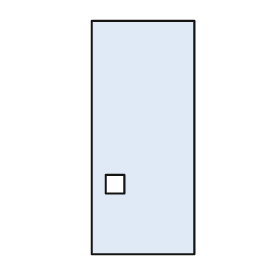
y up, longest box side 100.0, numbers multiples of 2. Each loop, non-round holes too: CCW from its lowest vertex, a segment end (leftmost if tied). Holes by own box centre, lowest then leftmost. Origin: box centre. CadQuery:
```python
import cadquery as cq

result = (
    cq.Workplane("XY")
    .moveTo(-22.0, -50.0)
    .lineTo(22.0, -50.0)
    .lineTo(22.0, 50.0)
    .lineTo(-22.0, 50.0)
    .close()
    .moveTo(-16.0, -24.0)
    .lineTo(-8.0, -24.0)
    .lineTo(-8.0, -16.0)
    .lineTo(-16.0, -16.0)
    .close()
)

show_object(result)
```